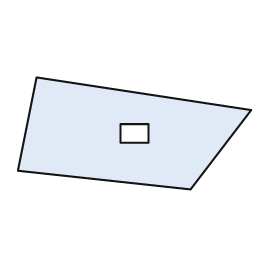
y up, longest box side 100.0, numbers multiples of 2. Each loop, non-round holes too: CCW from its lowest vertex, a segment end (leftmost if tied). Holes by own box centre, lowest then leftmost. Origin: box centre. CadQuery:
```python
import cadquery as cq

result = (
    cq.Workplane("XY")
    .moveTo(24.0, -24.0)
    .lineTo(50.0, 10.0)
    .lineTo(-42.0, 24.0)
    .lineTo(-50.0, -16.0)
    .close()
    .moveTo(-6.0, -4.0)
    .lineTo(6.0, -4.0)
    .lineTo(6.0, 4.0)
    .lineTo(-6.0, 4.0)
    .close()
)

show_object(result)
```